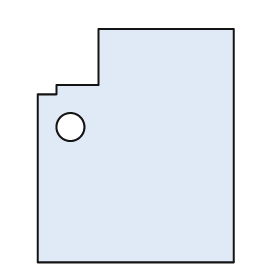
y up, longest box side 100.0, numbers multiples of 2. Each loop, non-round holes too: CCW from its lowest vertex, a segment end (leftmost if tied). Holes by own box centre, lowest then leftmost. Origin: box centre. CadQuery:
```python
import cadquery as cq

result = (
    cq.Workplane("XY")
    .moveTo(-42.0, -50.0)
    .lineTo(42.0, -50.0)
    .lineTo(42.0, 50.0)
    .lineTo(-16.0, 50.0)
    .lineTo(-16.0, 26.0)
    .lineTo(-34.0, 26.0)
    .lineTo(-34.0, 22.0)
    .lineTo(-42.0, 22.0)
    .close()
    .moveTo(-28.0, 8.0)
    .circle(6.0)
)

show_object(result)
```